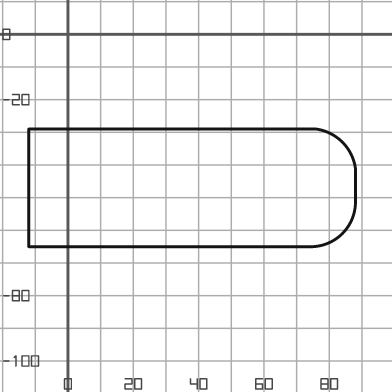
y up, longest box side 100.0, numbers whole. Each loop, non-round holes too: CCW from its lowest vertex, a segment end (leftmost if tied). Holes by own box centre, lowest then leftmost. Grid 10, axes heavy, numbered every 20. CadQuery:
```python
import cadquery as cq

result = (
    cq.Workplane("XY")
    .moveTo(-12.0, -65.0)
    .lineTo(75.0, -65.0)
    .threePointArc((84.0, -61.0), (88.0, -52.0))
    .lineTo(88.0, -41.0)
    .threePointArc((84.0, -33.0), (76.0, -29.0))
    .lineTo(-12.0, -29.0)
    .close()
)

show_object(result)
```